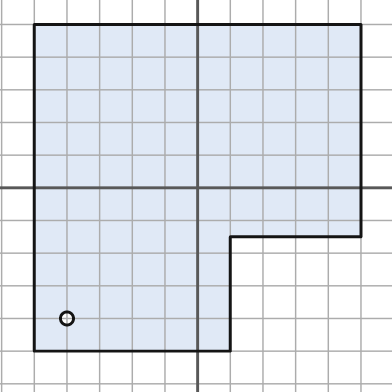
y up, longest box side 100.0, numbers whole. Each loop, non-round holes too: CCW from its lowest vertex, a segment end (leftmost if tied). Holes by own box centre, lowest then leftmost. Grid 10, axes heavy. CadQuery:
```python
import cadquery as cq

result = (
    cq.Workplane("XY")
    .moveTo(-50.0, -50.0)
    .lineTo(10.0, -50.0)
    .lineTo(10.0, -15.0)
    .lineTo(50.0, -15.0)
    .lineTo(50.0, 50.0)
    .lineTo(-50.0, 50.0)
    .close()
    .moveTo(-40.0, -40.0)
    .circle(2.0)
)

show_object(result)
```